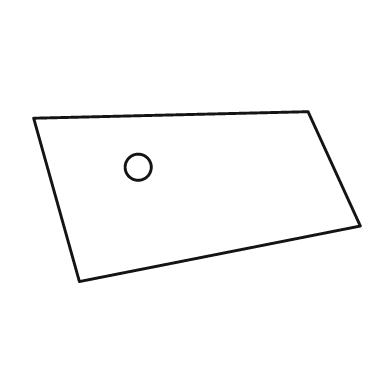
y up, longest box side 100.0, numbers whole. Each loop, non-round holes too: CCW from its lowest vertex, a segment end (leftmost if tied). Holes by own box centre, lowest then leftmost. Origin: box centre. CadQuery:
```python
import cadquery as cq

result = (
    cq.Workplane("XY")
    .moveTo(-36.0, -26.0)
    .lineTo(50.0, -9.0)
    .lineTo(34.0, 26.0)
    .lineTo(-50.0, 24.0)
    .close()
    .moveTo(-18.0, 9.0)
    .circle(4.0)
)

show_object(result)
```